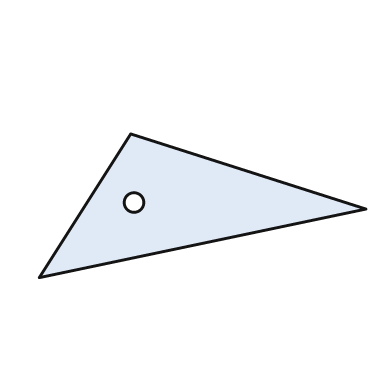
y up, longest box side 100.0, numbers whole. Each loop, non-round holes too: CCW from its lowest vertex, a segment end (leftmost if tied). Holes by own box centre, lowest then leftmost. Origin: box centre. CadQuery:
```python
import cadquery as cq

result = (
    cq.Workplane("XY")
    .moveTo(-50.0, -22.0)
    .lineTo(50.0, -1.0)
    .lineTo(-22.0, 22.0)
    .close()
    .moveTo(-21.0, 1.0)
    .circle(3.0)
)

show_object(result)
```